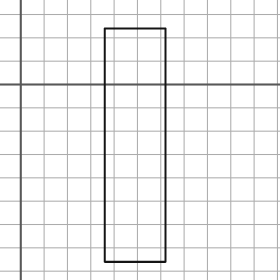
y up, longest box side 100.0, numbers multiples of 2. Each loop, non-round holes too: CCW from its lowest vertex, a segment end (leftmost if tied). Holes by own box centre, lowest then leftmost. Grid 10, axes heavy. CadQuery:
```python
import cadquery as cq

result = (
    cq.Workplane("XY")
    .moveTo(36.0, -76.0)
    .lineTo(62.0, -76.0)
    .lineTo(62.0, 24.0)
    .lineTo(36.0, 24.0)
    .close()
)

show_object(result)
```